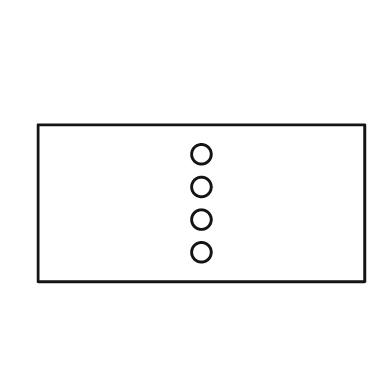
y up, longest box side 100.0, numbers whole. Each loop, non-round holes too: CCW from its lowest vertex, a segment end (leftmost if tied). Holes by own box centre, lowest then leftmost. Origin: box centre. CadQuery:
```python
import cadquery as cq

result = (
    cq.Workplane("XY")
    .moveTo(-50.0, -24.0)
    .lineTo(50.0, -24.0)
    .lineTo(50.0, 24.0)
    .lineTo(-50.0, 24.0)
    .close()
    .moveTo(0.0, -15.0)
    .circle(3.0)
    .moveTo(0.0, -5.0)
    .circle(3.0)
    .moveTo(0.0, 5.0)
    .circle(3.0)
    .moveTo(0.0, 15.0)
    .circle(3.0)
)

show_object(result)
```